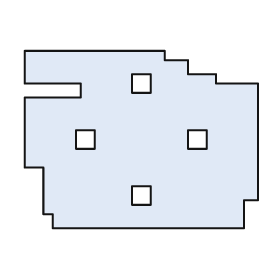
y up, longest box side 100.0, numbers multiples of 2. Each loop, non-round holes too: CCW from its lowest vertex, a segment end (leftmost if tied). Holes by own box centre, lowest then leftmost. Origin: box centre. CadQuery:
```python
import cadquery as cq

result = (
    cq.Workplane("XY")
    .moveTo(-38.0, -38.0)
    .lineTo(44.0, -38.0)
    .lineTo(44.0, -26.0)
    .lineTo(50.0, -26.0)
    .lineTo(50.0, 24.0)
    .lineTo(32.0, 24.0)
    .lineTo(32.0, 28.0)
    .lineTo(20.0, 28.0)
    .lineTo(20.0, 34.0)
    .lineTo(10.0, 34.0)
    .lineTo(10.0, 38.0)
    .lineTo(-50.0, 38.0)
    .lineTo(-50.0, 24.0)
    .lineTo(-26.0, 24.0)
    .lineTo(-26.0, 18.0)
    .lineTo(-50.0, 18.0)
    .lineTo(-50.0, -12.0)
    .lineTo(-42.0, -12.0)
    .lineTo(-42.0, -32.0)
    .lineTo(-38.0, -32.0)
    .close()
    .moveTo(-4.0, -28.0)
    .lineTo(4.0, -28.0)
    .lineTo(4.0, -20.0)
    .lineTo(-4.0, -20.0)
    .close()
    .moveTo(-28.0, -4.0)
    .lineTo(-20.0, -4.0)
    .lineTo(-20.0, 4.0)
    .lineTo(-28.0, 4.0)
    .close()
    .moveTo(20.0, -4.0)
    .lineTo(28.0, -4.0)
    .lineTo(28.0, 4.0)
    .lineTo(20.0, 4.0)
    .close()
    .moveTo(-4.0, 20.0)
    .lineTo(4.0, 20.0)
    .lineTo(4.0, 28.0)
    .lineTo(-4.0, 28.0)
    .close()
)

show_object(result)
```